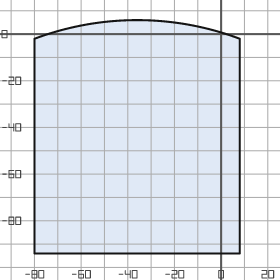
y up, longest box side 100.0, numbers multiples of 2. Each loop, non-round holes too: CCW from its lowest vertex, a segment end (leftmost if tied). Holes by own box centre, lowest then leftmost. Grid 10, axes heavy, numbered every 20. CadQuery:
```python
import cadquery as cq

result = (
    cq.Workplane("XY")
    .moveTo(-80.0, -94.0)
    .lineTo(8.0, -94.0)
    .lineTo(8.0, -2.0)
    .threePointArc((-36.0, 6.0), (-80.0, -2.0))
    .close()
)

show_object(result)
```